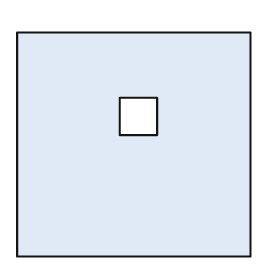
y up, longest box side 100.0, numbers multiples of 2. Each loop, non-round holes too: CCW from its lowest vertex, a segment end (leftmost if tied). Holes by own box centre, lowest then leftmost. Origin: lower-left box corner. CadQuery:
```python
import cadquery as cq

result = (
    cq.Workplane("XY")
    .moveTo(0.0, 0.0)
    .lineTo(100.0, 0.0)
    .lineTo(100.0, 96.0)
    .lineTo(0.0, 96.0)
    .close()
    .moveTo(44.0, 52.0)
    .lineTo(60.0, 52.0)
    .lineTo(60.0, 68.0)
    .lineTo(44.0, 68.0)
    .close()
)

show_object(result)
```